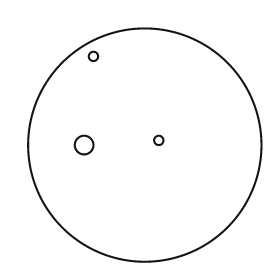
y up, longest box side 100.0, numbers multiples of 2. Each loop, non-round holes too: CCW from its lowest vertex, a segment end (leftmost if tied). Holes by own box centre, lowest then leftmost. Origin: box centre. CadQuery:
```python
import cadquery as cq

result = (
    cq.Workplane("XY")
    .moveTo(0.0, 0.0)
    .circle(50.0)
    .moveTo(-26.0, 0.0)
    .circle(4.0)
    .moveTo(6.0, 2.0)
    .circle(2.0)
    .moveTo(-22.0, 38.0)
    .circle(2.0)
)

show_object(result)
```